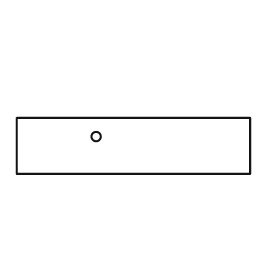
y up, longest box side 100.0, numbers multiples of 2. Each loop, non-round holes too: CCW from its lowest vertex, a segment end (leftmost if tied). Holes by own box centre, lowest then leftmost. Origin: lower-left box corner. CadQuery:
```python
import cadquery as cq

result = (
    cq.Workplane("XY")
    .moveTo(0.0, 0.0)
    .lineTo(100.0, 0.0)
    .lineTo(100.0, 24.0)
    .lineTo(0.0, 24.0)
    .close()
    .moveTo(34.0, 16.0)
    .circle(2.0)
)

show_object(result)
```